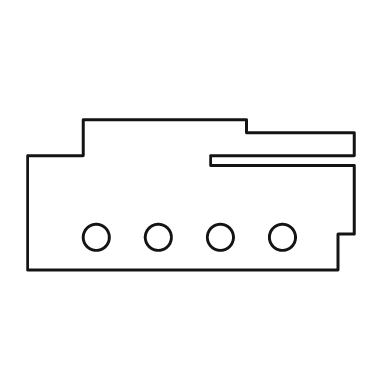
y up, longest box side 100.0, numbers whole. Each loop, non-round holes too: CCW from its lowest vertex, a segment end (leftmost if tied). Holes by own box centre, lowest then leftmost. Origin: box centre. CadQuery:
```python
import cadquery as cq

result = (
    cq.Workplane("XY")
    .moveTo(-50.0, -23.0)
    .lineTo(45.0, -23.0)
    .lineTo(45.0, -12.0)
    .lineTo(50.0, -12.0)
    .lineTo(50.0, 9.0)
    .lineTo(6.0, 9.0)
    .lineTo(6.0, 12.0)
    .lineTo(50.0, 12.0)
    .lineTo(50.0, 19.0)
    .lineTo(17.0, 19.0)
    .lineTo(17.0, 23.0)
    .lineTo(-33.0, 23.0)
    .lineTo(-33.0, 12.0)
    .lineTo(-50.0, 12.0)
    .close()
    .moveTo(-29.0, -13.0)
    .circle(4.0)
    .moveTo(-10.0, -13.0)
    .circle(4.0)
    .moveTo(9.0, -13.0)
    .circle(4.0)
    .moveTo(28.0, -13.0)
    .circle(4.0)
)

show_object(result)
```